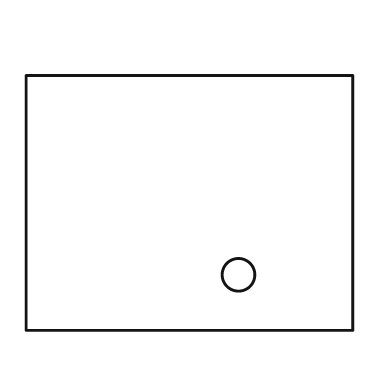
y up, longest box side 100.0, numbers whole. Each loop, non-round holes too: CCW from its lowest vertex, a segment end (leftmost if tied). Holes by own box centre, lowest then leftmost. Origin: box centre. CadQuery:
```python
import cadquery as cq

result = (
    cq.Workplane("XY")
    .moveTo(-50.0, -39.0)
    .lineTo(50.0, -39.0)
    .lineTo(50.0, 39.0)
    .lineTo(-50.0, 39.0)
    .close()
    .moveTo(15.0, -22.0)
    .circle(5.0)
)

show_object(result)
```